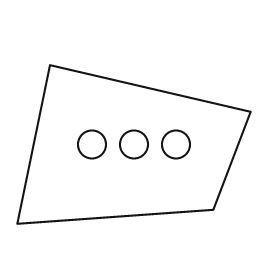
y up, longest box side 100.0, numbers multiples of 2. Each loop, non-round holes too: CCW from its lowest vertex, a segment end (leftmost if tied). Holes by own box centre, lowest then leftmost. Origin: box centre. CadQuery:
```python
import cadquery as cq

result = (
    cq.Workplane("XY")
    .moveTo(-50.0, -34.0)
    .lineTo(34.0, -28.0)
    .lineTo(50.0, 14.0)
    .lineTo(-36.0, 34.0)
    .close()
    .moveTo(-18.0, 0.0)
    .circle(6.0)
    .moveTo(0.0, 0.0)
    .circle(6.0)
    .moveTo(18.0, 0.0)
    .circle(6.0)
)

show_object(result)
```